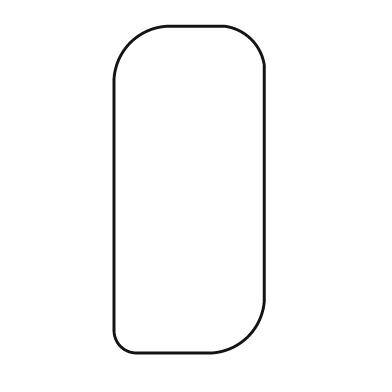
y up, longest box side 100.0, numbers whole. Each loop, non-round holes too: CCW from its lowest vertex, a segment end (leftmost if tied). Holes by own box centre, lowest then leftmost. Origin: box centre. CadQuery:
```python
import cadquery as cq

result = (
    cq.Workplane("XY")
    .moveTo(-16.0, -50.0)
    .lineTo(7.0, -50.0)
    .threePointArc((18.0, -45.0), (23.0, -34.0))
    .lineTo(23.0, 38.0)
    .threePointArc((19.0, 46.0), (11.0, 50.0))
    .lineTo(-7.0, 50.0)
    .threePointArc((-18.0, 45.0), (-23.0, 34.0))
    .lineTo(-23.0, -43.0)
    .threePointArc((-21.0, -48.0), (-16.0, -50.0))
    .close()
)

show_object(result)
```